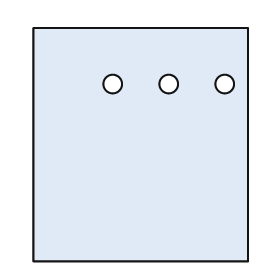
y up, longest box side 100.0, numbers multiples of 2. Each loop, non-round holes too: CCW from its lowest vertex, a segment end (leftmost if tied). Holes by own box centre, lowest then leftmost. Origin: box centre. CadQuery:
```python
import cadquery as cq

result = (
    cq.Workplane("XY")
    .moveTo(-46.0, -50.0)
    .lineTo(46.0, -50.0)
    .lineTo(46.0, 50.0)
    .lineTo(-46.0, 50.0)
    .close()
    .moveTo(-12.0, 26.0)
    .circle(4.0)
    .moveTo(12.0, 26.0)
    .circle(4.0)
    .moveTo(36.0, 26.0)
    .circle(4.0)
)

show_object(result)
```